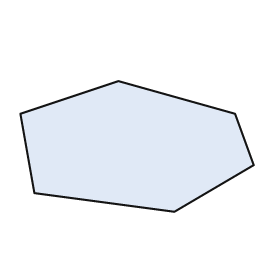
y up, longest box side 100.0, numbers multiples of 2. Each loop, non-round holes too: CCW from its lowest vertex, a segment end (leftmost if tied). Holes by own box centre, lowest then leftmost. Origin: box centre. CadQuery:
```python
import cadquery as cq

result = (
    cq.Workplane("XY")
    .moveTo(16.0, -28.0)
    .lineTo(50.0, -8.0)
    .lineTo(42.0, 14.0)
    .lineTo(-8.0, 28.0)
    .lineTo(-50.0, 14.0)
    .lineTo(-44.0, -20.0)
    .close()
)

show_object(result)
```